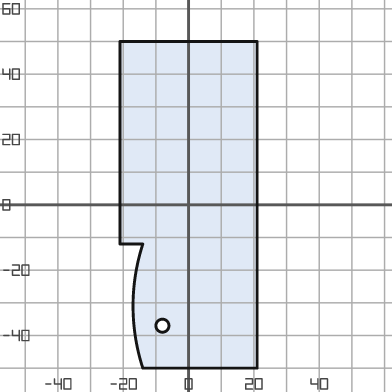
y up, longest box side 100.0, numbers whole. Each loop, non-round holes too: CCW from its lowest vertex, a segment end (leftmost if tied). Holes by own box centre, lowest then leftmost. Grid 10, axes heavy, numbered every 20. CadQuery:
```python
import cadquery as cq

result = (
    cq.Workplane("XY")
    .moveTo(-14.0, -50.0)
    .lineTo(21.0, -50.0)
    .lineTo(21.0, 50.0)
    .lineTo(-21.0, 50.0)
    .lineTo(-21.0, -12.0)
    .lineTo(-14.0, -12.0)
    .threePointArc((-17.0, -31.0), (-14.0, -50.0))
    .close()
    .moveTo(-8.0, -37.0)
    .circle(2.0)
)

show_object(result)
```